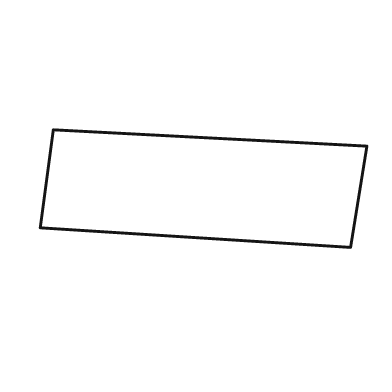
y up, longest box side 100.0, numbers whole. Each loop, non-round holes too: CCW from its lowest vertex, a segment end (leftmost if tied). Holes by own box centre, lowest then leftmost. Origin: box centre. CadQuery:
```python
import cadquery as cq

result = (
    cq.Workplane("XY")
    .moveTo(45.0, -18.0)
    .lineTo(50.0, 13.0)
    .lineTo(-46.0, 18.0)
    .lineTo(-50.0, -12.0)
    .close()
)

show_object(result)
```